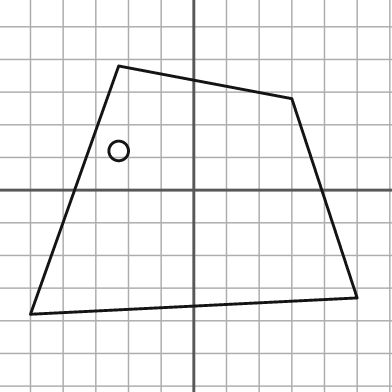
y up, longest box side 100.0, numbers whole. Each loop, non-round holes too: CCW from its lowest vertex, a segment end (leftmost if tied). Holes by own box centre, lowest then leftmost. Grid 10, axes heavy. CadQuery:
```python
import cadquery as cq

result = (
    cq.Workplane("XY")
    .moveTo(-50.0, -38.0)
    .lineTo(50.0, -33.0)
    .lineTo(30.0, 28.0)
    .lineTo(-23.0, 38.0)
    .close()
    .moveTo(-23.0, 12.0)
    .circle(3.0)
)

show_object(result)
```